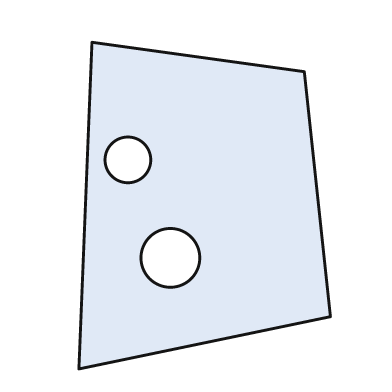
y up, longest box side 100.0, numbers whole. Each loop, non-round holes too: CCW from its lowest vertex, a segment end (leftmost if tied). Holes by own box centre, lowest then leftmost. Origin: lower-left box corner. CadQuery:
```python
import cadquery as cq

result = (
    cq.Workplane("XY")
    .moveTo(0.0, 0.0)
    .lineTo(77.0, 16.0)
    .lineTo(69.0, 91.0)
    .lineTo(4.0, 100.0)
    .close()
    .moveTo(28.0, 34.0)
    .circle(9.0)
    .moveTo(15.0, 64.0)
    .circle(7.0)
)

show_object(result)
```